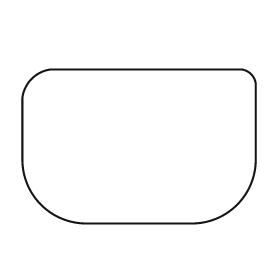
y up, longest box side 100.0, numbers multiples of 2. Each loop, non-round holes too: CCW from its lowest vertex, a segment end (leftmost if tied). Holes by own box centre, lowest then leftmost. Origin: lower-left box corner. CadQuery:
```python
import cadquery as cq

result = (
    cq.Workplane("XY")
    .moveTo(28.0, 0.0)
    .lineTo(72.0, 0.0)
    .threePointArc((92.0, 8.0), (100.0, 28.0))
    .lineTo(100.0, 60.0)
    .threePointArc((98.0, 64.0), (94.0, 66.0))
    .lineTo(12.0, 66.0)
    .threePointArc((4.0, 62.0), (0.0, 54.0))
    .lineTo(0.0, 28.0)
    .threePointArc((8.0, 8.0), (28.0, 0.0))
    .close()
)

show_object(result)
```